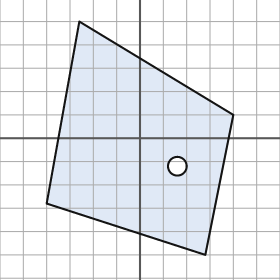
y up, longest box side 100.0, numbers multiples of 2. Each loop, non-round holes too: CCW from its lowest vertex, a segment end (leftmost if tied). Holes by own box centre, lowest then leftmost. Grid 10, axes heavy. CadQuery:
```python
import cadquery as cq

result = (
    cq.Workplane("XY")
    .moveTo(28.0, -50.0)
    .lineTo(40.0, 10.0)
    .lineTo(-26.0, 50.0)
    .lineTo(-40.0, -28.0)
    .close()
    .moveTo(16.0, -12.0)
    .circle(4.0)
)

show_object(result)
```